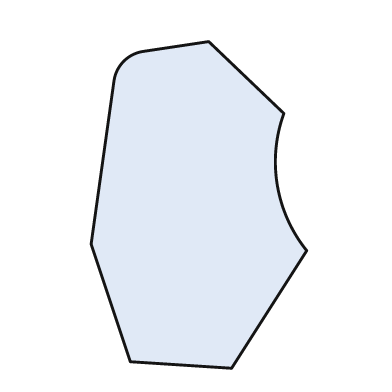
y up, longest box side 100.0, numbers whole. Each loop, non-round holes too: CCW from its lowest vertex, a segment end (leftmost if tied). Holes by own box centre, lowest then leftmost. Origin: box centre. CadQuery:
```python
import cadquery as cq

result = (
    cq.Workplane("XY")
    .moveTo(10.0, -50.0)
    .lineTo(33.0, -14.0)
    .threePointArc((24.0, 6.0), (26.0, 28.0))
    .lineTo(3.0, 50.0)
    .lineTo(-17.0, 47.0)
    .threePointArc((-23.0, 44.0), (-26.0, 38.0))
    .lineTo(-33.0, -12.0)
    .lineTo(-21.0, -48.0)
    .close()
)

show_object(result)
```